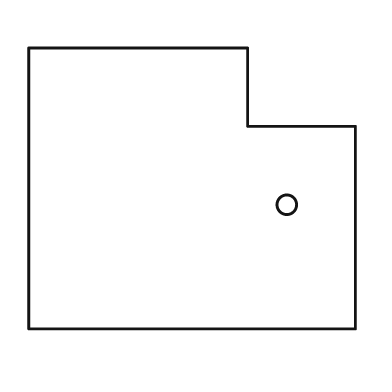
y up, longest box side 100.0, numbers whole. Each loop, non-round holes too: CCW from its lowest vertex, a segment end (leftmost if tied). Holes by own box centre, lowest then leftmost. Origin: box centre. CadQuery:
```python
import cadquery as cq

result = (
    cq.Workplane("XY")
    .moveTo(-50.0, -43.0)
    .lineTo(50.0, -43.0)
    .lineTo(50.0, 19.0)
    .lineTo(17.0, 19.0)
    .lineTo(17.0, 43.0)
    .lineTo(-50.0, 43.0)
    .close()
    .moveTo(29.0, -5.0)
    .circle(3.0)
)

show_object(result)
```